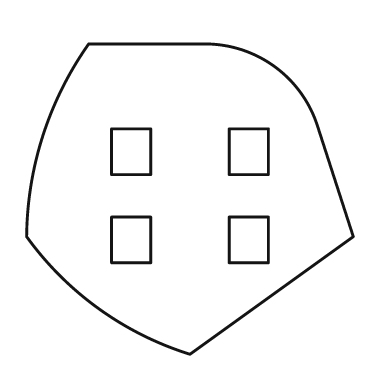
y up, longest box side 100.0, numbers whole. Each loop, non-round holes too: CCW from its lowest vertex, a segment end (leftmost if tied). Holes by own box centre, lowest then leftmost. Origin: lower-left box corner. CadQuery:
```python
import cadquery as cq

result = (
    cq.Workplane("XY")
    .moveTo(50.0, 0.0)
    .lineTo(100.0, 36.0)
    .lineTo(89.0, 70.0)
    .threePointArc((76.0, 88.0), (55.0, 95.0))
    .lineTo(19.0, 95.0)
    .threePointArc((5.0, 67.0), (0.0, 36.0))
    .threePointArc((22.0, 14.0), (50.0, 0.0))
    .close()
    .moveTo(26.0, 28.0)
    .lineTo(38.0, 28.0)
    .lineTo(38.0, 42.0)
    .lineTo(26.0, 42.0)
    .close()
    .moveTo(62.0, 28.0)
    .lineTo(74.0, 28.0)
    .lineTo(74.0, 42.0)
    .lineTo(62.0, 42.0)
    .close()
    .moveTo(26.0, 55.0)
    .lineTo(38.0, 55.0)
    .lineTo(38.0, 69.0)
    .lineTo(26.0, 69.0)
    .close()
    .moveTo(62.0, 55.0)
    .lineTo(74.0, 55.0)
    .lineTo(74.0, 69.0)
    .lineTo(62.0, 69.0)
    .close()
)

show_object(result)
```